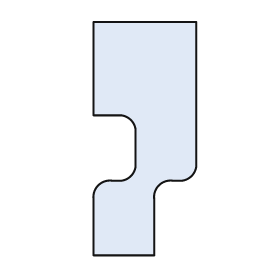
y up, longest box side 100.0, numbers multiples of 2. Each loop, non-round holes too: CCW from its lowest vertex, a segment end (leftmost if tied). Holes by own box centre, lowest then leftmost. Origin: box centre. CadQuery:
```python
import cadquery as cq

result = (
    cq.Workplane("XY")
    .moveTo(-22.0, -50.0)
    .lineTo(4.0, -50.0)
    .lineTo(4.0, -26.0)
    .threePointArc((6.0, -20.0), (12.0, -18.0))
    .lineTo(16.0, -18.0)
    .threePointArc((20.0, -16.0), (22.0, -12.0))
    .lineTo(22.0, 50.0)
    .lineTo(-22.0, 50.0)
    .lineTo(-22.0, 10.0)
    .lineTo(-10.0, 10.0)
    .threePointArc((-6.0, 8.0), (-4.0, 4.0))
    .lineTo(-4.0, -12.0)
    .threePointArc((-6.0, -16.0), (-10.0, -18.0))
    .lineTo(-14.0, -18.0)
    .threePointArc((-20.0, -20.0), (-22.0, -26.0))
    .close()
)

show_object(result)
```